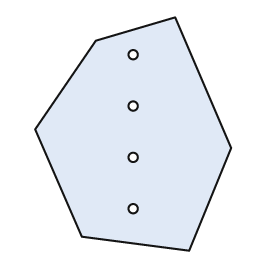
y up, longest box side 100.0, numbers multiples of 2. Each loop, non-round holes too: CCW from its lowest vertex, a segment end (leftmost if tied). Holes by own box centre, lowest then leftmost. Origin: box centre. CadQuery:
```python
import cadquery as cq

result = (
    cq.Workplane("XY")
    .moveTo(24.0, -50.0)
    .lineTo(42.0, -6.0)
    .lineTo(18.0, 50.0)
    .lineTo(-16.0, 40.0)
    .lineTo(-42.0, 2.0)
    .lineTo(-22.0, -44.0)
    .close()
    .moveTo(0.0, -32.0)
    .circle(2.0)
    .moveTo(0.0, -10.0)
    .circle(2.0)
    .moveTo(0.0, 12.0)
    .circle(2.0)
    .moveTo(0.0, 34.0)
    .circle(2.0)
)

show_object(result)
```